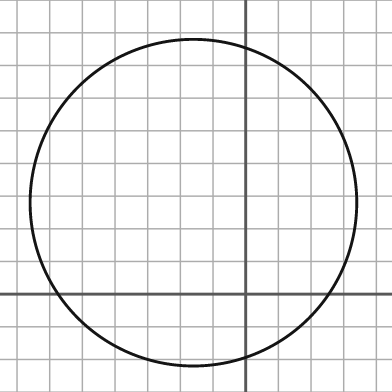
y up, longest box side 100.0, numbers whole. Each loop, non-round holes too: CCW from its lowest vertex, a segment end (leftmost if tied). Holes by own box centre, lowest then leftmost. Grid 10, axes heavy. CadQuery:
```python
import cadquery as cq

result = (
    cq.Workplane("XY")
    .moveTo(-16.0, 28.0)
    .circle(50.0)
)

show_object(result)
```